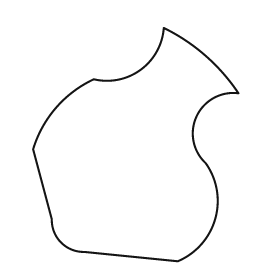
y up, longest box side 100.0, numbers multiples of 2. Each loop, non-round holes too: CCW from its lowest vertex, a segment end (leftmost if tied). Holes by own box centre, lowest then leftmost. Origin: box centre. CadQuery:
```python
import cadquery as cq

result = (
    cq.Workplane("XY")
    .moveTo(18.0, -50.0)
    .threePointArc((34.0, -32.0), (30.0, -8.0))
    .threePointArc((26.0, 12.0), (44.0, 22.0))
    .threePointArc((30.0, 38.0), (12.0, 50.0))
    .threePointArc((2.0, 32.0), (-18.0, 28.0))
    .threePointArc((-34.0, 16.0), (-44.0, -2.0))
    .lineTo(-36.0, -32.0)
    .threePointArc((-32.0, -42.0), (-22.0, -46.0))
    .close()
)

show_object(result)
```